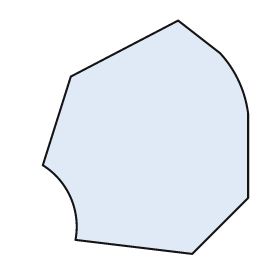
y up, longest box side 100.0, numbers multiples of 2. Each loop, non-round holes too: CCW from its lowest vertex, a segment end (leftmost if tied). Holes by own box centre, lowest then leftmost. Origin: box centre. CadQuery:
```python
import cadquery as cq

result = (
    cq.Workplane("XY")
    .moveTo(20.0, -50.0)
    .lineTo(44.0, -26.0)
    .lineTo(44.0, 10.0)
    .threePointArc((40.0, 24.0), (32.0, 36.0))
    .lineTo(14.0, 50.0)
    .lineTo(-32.0, 26.0)
    .lineTo(-44.0, -12.0)
    .threePointArc((-32.0, -26.0), (-30.0, -44.0))
    .close()
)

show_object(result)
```